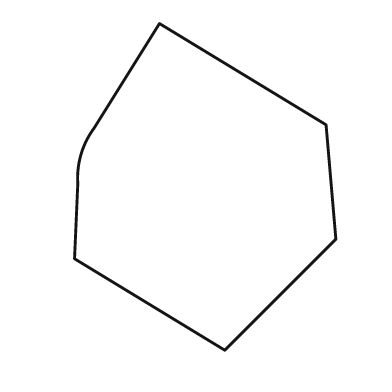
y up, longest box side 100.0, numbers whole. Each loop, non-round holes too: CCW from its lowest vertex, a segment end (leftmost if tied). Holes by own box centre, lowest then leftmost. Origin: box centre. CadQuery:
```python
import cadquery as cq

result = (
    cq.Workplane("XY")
    .moveTo(6.0, -50.0)
    .lineTo(40.0, -16.0)
    .lineTo(37.0, 19.0)
    .lineTo(-14.0, 50.0)
    .lineTo(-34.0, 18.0)
    .threePointArc((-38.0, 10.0), (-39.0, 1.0))
    .lineTo(-40.0, -22.0)
    .close()
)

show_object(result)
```